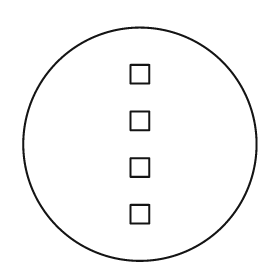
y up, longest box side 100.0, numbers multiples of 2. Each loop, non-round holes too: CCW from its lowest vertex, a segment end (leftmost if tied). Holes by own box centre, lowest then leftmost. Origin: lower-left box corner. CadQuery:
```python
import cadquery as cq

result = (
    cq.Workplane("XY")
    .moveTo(50.0, 50.0)
    .circle(50.0)
    .moveTo(46.0, 16.0)
    .lineTo(54.0, 16.0)
    .lineTo(54.0, 24.0)
    .lineTo(46.0, 24.0)
    .close()
    .moveTo(46.0, 36.0)
    .lineTo(54.0, 36.0)
    .lineTo(54.0, 44.0)
    .lineTo(46.0, 44.0)
    .close()
    .moveTo(46.0, 56.0)
    .lineTo(54.0, 56.0)
    .lineTo(54.0, 64.0)
    .lineTo(46.0, 64.0)
    .close()
    .moveTo(46.0, 76.0)
    .lineTo(54.0, 76.0)
    .lineTo(54.0, 84.0)
    .lineTo(46.0, 84.0)
    .close()
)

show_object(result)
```